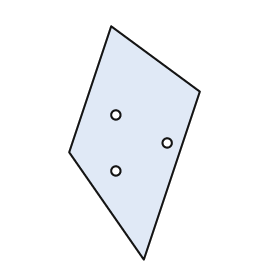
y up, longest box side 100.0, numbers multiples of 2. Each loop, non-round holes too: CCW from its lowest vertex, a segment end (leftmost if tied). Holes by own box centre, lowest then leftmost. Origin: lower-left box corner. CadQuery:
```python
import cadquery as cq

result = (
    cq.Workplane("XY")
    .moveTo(32.0, 0.0)
    .lineTo(56.0, 72.0)
    .lineTo(18.0, 100.0)
    .lineTo(0.0, 46.0)
    .close()
    .moveTo(20.0, 38.0)
    .circle(2.0)
    .moveTo(42.0, 50.0)
    .circle(2.0)
    .moveTo(20.0, 62.0)
    .circle(2.0)
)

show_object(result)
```